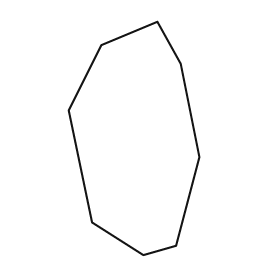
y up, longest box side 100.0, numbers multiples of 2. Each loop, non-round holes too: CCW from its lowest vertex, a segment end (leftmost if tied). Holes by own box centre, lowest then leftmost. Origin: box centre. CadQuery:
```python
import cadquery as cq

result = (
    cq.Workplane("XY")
    .moveTo(4.0, -50.0)
    .lineTo(18.0, -46.0)
    .lineTo(28.0, -8.0)
    .lineTo(20.0, 32.0)
    .lineTo(10.0, 50.0)
    .lineTo(-14.0, 40.0)
    .lineTo(-28.0, 12.0)
    .lineTo(-18.0, -36.0)
    .close()
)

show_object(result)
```